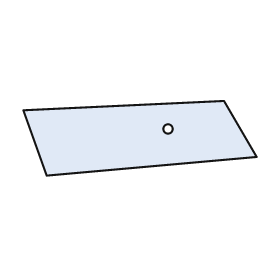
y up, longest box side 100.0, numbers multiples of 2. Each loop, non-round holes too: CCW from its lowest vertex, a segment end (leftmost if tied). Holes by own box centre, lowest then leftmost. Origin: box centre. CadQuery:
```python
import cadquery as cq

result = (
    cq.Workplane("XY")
    .moveTo(-40.0, -16.0)
    .lineTo(50.0, -8.0)
    .lineTo(36.0, 16.0)
    .lineTo(-50.0, 12.0)
    .close()
    .moveTo(12.0, 4.0)
    .circle(2.0)
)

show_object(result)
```